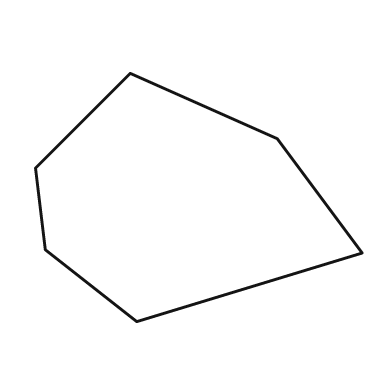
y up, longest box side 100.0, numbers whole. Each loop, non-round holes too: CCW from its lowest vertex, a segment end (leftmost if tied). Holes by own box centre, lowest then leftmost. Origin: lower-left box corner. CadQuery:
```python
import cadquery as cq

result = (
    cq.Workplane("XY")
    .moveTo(31.0, 0.0)
    .lineTo(100.0, 21.0)
    .lineTo(74.0, 56.0)
    .lineTo(29.0, 76.0)
    .lineTo(0.0, 47.0)
    .lineTo(3.0, 22.0)
    .close()
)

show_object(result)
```